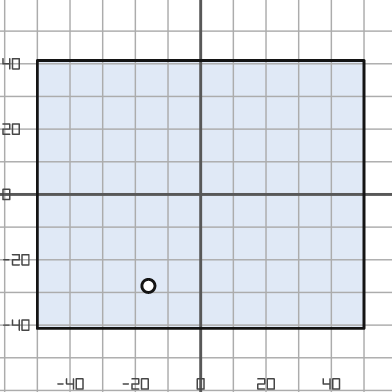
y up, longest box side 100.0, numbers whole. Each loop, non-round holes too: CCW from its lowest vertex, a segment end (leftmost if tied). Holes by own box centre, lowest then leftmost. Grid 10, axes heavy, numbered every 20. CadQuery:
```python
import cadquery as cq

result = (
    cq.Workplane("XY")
    .moveTo(-50.0, -41.0)
    .lineTo(50.0, -41.0)
    .lineTo(50.0, 41.0)
    .lineTo(-50.0, 41.0)
    .close()
    .moveTo(-16.0, -28.0)
    .circle(2.0)
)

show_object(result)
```